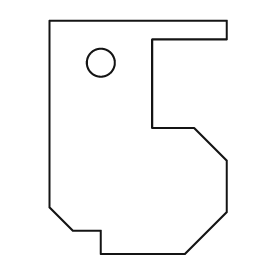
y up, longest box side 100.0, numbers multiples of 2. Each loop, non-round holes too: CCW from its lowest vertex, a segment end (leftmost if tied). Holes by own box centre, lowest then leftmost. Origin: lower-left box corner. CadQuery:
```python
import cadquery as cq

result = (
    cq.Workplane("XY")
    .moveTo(22.0, 0.0)
    .lineTo(58.0, 0.0)
    .lineTo(76.0, 18.0)
    .lineTo(76.0, 40.0)
    .lineTo(62.0, 54.0)
    .lineTo(44.0, 54.0)
    .lineTo(44.0, 92.0)
    .lineTo(76.0, 92.0)
    .lineTo(76.0, 100.0)
    .lineTo(0.0, 100.0)
    .lineTo(0.0, 20.0)
    .lineTo(10.0, 10.0)
    .lineTo(22.0, 10.0)
    .close()
    .moveTo(22.0, 82.0)
    .circle(6.0)
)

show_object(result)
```